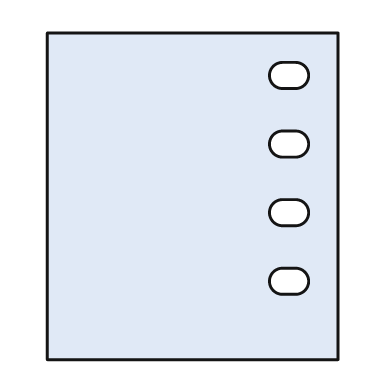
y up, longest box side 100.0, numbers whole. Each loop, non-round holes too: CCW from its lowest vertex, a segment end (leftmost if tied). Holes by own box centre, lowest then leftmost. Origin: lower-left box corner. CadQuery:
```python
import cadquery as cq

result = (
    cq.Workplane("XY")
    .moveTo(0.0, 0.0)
    .lineTo(89.0, 0.0)
    .lineTo(89.0, 100.0)
    .lineTo(0.0, 100.0)
    .close()
    .moveTo(72.0, 20.0)
    .lineTo(76.0, 20.0)
    .threePointArc((80.0, 24.0), (76.0, 28.0))
    .lineTo(72.0, 28.0)
    .threePointArc((68.0, 24.0), (72.0, 20.0))
    .close()
    .moveTo(72.0, 41.0)
    .lineTo(76.0, 41.0)
    .threePointArc((80.0, 45.0), (76.0, 49.0))
    .lineTo(72.0, 49.0)
    .threePointArc((68.0, 45.0), (72.0, 41.0))
    .close()
    .moveTo(72.0, 62.0)
    .lineTo(76.0, 62.0)
    .threePointArc((80.0, 66.0), (76.0, 70.0))
    .lineTo(72.0, 70.0)
    .threePointArc((68.0, 66.0), (72.0, 62.0))
    .close()
    .moveTo(72.0, 83.0)
    .lineTo(76.0, 83.0)
    .threePointArc((80.0, 87.0), (76.0, 91.0))
    .lineTo(72.0, 91.0)
    .threePointArc((68.0, 87.0), (72.0, 83.0))
    .close()
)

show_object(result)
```